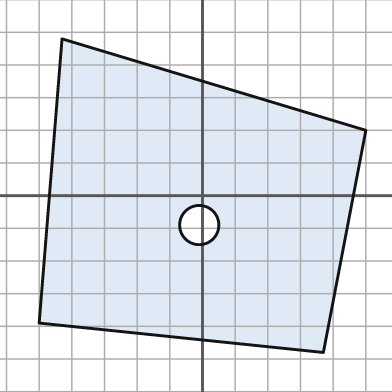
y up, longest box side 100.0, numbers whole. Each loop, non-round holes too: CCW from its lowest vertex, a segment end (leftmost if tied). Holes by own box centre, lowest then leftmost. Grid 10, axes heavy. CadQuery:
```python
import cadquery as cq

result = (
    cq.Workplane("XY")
    .moveTo(37.0, -48.0)
    .lineTo(50.0, 20.0)
    .lineTo(-43.0, 48.0)
    .lineTo(-50.0, -39.0)
    .close()
    .moveTo(-1.0, -9.0)
    .circle(6.0)
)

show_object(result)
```